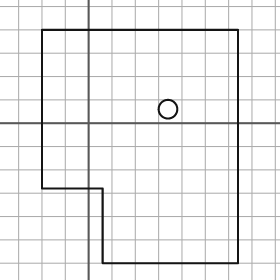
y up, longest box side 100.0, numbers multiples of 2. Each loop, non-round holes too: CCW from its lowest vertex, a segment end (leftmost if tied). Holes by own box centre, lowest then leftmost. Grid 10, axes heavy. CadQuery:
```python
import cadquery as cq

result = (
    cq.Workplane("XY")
    .moveTo(6.0, -60.0)
    .lineTo(64.0, -60.0)
    .lineTo(64.0, 40.0)
    .lineTo(-20.0, 40.0)
    .lineTo(-20.0, -28.0)
    .lineTo(6.0, -28.0)
    .close()
    .moveTo(34.0, 6.0)
    .circle(4.0)
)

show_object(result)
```